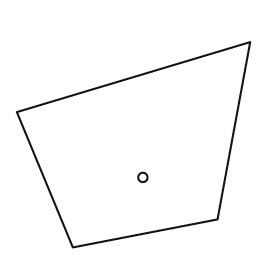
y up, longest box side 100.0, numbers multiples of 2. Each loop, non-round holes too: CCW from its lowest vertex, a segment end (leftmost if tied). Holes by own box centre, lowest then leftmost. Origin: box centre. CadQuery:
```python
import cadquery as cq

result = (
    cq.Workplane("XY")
    .moveTo(-26.0, -44.0)
    .lineTo(36.0, -32.0)
    .lineTo(50.0, 44.0)
    .lineTo(-50.0, 14.0)
    .close()
    .moveTo(4.0, -14.0)
    .circle(2.0)
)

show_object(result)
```